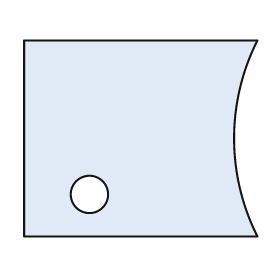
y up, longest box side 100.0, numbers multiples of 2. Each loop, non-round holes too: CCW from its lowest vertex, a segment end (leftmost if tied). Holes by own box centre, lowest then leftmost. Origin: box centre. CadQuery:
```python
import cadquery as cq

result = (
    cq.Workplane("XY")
    .moveTo(-50.0, -42.0)
    .lineTo(50.0, -42.0)
    .threePointArc((40.0, 0.0), (50.0, 42.0))
    .lineTo(-50.0, 42.0)
    .close()
    .moveTo(-22.0, -24.0)
    .circle(8.0)
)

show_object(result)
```